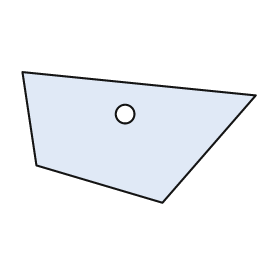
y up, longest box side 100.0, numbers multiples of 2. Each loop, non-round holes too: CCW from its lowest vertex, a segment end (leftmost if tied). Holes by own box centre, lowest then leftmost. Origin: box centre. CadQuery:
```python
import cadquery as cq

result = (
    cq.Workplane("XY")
    .moveTo(10.0, -28.0)
    .lineTo(50.0, 18.0)
    .lineTo(-50.0, 28.0)
    .lineTo(-44.0, -12.0)
    .close()
    .moveTo(-6.0, 10.0)
    .circle(4.0)
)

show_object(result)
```